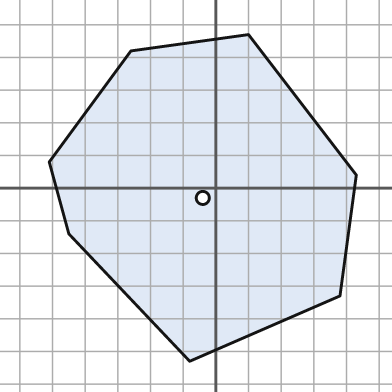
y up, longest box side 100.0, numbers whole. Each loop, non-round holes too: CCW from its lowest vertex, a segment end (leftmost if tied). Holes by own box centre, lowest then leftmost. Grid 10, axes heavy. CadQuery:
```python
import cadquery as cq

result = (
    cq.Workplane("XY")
    .moveTo(-8.0, -53.0)
    .lineTo(38.0, -33.0)
    .lineTo(43.0, 4.0)
    .lineTo(10.0, 47.0)
    .lineTo(-26.0, 42.0)
    .lineTo(-51.0, 8.0)
    .lineTo(-45.0, -14.0)
    .close()
    .moveTo(-4.0, -3.0)
    .circle(2.0)
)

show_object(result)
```